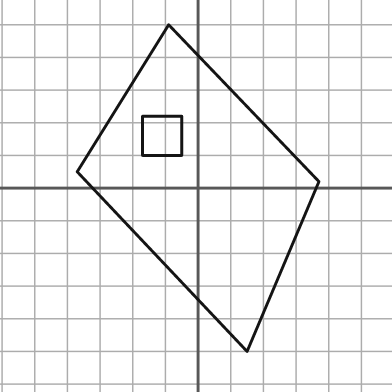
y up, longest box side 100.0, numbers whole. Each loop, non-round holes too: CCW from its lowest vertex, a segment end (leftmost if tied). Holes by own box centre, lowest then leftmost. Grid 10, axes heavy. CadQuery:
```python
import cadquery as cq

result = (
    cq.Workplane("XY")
    .moveTo(15.0, -50.0)
    .lineTo(37.0, 2.0)
    .lineTo(-9.0, 50.0)
    .lineTo(-37.0, 5.0)
    .close()
    .moveTo(-17.0, 10.0)
    .lineTo(-5.0, 10.0)
    .lineTo(-5.0, 22.0)
    .lineTo(-17.0, 22.0)
    .close()
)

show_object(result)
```